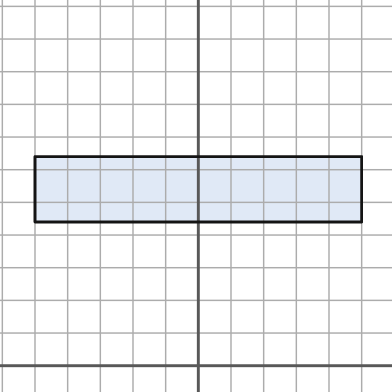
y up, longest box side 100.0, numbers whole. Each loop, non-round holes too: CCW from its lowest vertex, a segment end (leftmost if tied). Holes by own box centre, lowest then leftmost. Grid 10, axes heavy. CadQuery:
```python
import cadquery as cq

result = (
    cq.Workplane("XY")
    .moveTo(-50.0, 44.0)
    .lineTo(50.0, 44.0)
    .lineTo(50.0, 64.0)
    .lineTo(-50.0, 64.0)
    .close()
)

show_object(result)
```